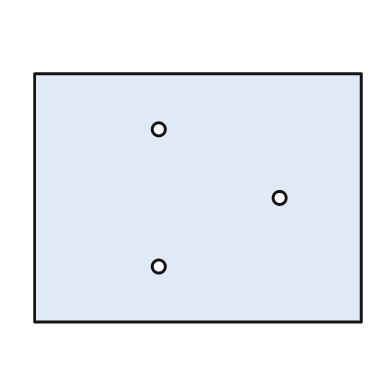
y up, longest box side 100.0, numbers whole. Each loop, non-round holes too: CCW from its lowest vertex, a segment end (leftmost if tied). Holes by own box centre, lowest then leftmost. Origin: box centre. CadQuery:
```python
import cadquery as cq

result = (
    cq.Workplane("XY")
    .moveTo(-50.0, -38.0)
    .lineTo(50.0, -38.0)
    .lineTo(50.0, 38.0)
    .lineTo(-50.0, 38.0)
    .close()
    .moveTo(-12.0, -21.0)
    .circle(2.0)
    .moveTo(25.0, 0.0)
    .circle(2.0)
    .moveTo(-12.0, 21.0)
    .circle(2.0)
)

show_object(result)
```